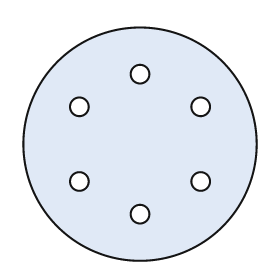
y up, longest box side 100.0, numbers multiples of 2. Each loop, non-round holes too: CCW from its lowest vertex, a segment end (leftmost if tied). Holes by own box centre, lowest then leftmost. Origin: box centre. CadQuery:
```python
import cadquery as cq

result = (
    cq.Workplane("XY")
    .moveTo(0.0, 0.0)
    .circle(50.0)
    .moveTo(0.0, -30.0)
    .circle(4.0)
    .moveTo(-26.0, -16.0)
    .circle(4.0)
    .moveTo(26.0, -16.0)
    .circle(4.0)
    .moveTo(-26.0, 16.0)
    .circle(4.0)
    .moveTo(26.0, 16.0)
    .circle(4.0)
    .moveTo(0.0, 30.0)
    .circle(4.0)
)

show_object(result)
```